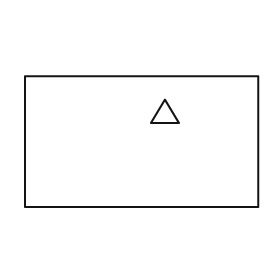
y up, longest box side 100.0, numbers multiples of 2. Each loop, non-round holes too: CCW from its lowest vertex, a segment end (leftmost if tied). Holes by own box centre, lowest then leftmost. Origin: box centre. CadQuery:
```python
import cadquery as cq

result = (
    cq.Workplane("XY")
    .moveTo(-50.0, -28.0)
    .lineTo(50.0, -28.0)
    .lineTo(50.0, 28.0)
    .lineTo(-50.0, 28.0)
    .close()
    .moveTo(4.0, 8.0)
    .lineTo(16.0, 8.0)
    .lineTo(10.0, 18.0)
    .close()
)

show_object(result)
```